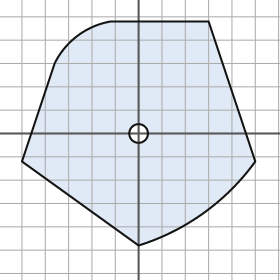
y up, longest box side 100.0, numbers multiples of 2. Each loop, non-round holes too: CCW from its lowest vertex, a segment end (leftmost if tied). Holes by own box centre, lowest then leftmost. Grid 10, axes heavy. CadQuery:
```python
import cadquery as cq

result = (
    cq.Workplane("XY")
    .moveTo(0.0, -48.0)
    .threePointArc((28.0, -34.0), (50.0, -12.0))
    .lineTo(30.0, 48.0)
    .lineTo(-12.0, 48.0)
    .threePointArc((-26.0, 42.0), (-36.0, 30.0))
    .lineTo(-50.0, -12.0)
    .close()
    .moveTo(0.0, 0.0)
    .circle(4.0)
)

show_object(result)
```